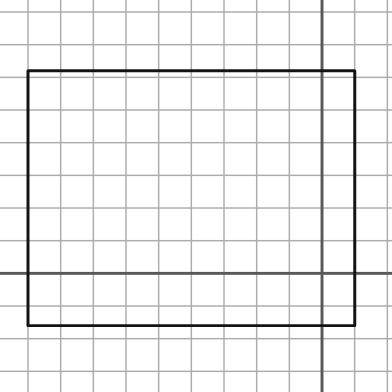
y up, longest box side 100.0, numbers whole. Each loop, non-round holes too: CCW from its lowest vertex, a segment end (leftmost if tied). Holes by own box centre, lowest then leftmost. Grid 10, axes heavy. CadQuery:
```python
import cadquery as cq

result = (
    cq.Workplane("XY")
    .moveTo(-90.0, -16.0)
    .lineTo(10.0, -16.0)
    .lineTo(10.0, 62.0)
    .lineTo(-90.0, 62.0)
    .close()
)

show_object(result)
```